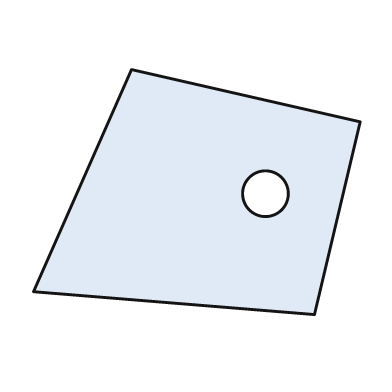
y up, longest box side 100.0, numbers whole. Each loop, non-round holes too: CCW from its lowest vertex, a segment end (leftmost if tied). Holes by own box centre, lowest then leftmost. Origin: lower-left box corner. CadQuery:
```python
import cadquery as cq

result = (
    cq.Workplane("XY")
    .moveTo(86.0, 0.0)
    .lineTo(100.0, 59.0)
    .lineTo(30.0, 75.0)
    .lineTo(0.0, 7.0)
    .close()
    .moveTo(71.0, 37.0)
    .circle(7.0)
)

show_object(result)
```